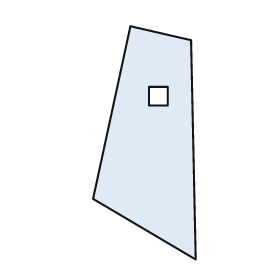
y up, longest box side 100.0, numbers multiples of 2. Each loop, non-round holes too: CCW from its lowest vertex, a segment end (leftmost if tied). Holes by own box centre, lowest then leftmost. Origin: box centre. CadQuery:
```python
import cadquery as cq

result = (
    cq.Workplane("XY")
    .moveTo(22.0, -50.0)
    .lineTo(20.0, 44.0)
    .lineTo(-6.0, 50.0)
    .lineTo(-22.0, -24.0)
    .close()
    .moveTo(2.0, 16.0)
    .lineTo(10.0, 16.0)
    .lineTo(10.0, 24.0)
    .lineTo(2.0, 24.0)
    .close()
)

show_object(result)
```